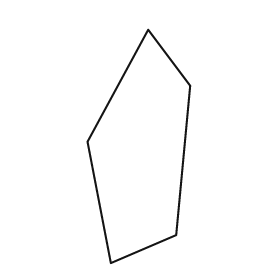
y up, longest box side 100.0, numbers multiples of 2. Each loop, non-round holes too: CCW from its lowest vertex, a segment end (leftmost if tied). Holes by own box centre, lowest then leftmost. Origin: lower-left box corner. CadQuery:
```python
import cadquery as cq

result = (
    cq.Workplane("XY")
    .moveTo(10.0, 0.0)
    .lineTo(38.0, 12.0)
    .lineTo(44.0, 76.0)
    .lineTo(26.0, 100.0)
    .lineTo(0.0, 52.0)
    .close()
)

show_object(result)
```